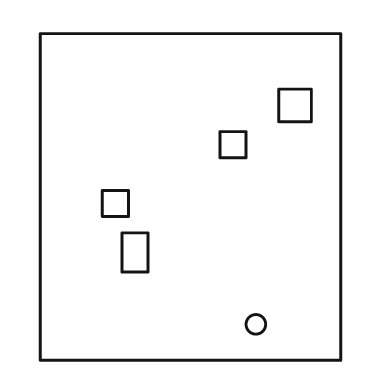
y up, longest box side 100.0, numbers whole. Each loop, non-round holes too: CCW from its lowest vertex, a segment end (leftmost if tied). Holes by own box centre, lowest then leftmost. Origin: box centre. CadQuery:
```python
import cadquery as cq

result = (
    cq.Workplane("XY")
    .moveTo(-46.0, -50.0)
    .lineTo(46.0, -50.0)
    .lineTo(46.0, 50.0)
    .lineTo(-46.0, 50.0)
    .close()
    .moveTo(20.0, -39.0)
    .circle(3.0)
    .moveTo(-21.0, -23.0)
    .lineTo(-13.0, -23.0)
    .lineTo(-13.0, -11.0)
    .lineTo(-21.0, -11.0)
    .close()
    .moveTo(-27.0, -6.0)
    .lineTo(-19.0, -6.0)
    .lineTo(-19.0, 2.0)
    .lineTo(-27.0, 2.0)
    .close()
    .moveTo(9.0, 12.0)
    .lineTo(17.0, 12.0)
    .lineTo(17.0, 20.0)
    .lineTo(9.0, 20.0)
    .close()
    .moveTo(27.0, 23.0)
    .lineTo(37.0, 23.0)
    .lineTo(37.0, 33.0)
    .lineTo(27.0, 33.0)
    .close()
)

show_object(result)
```